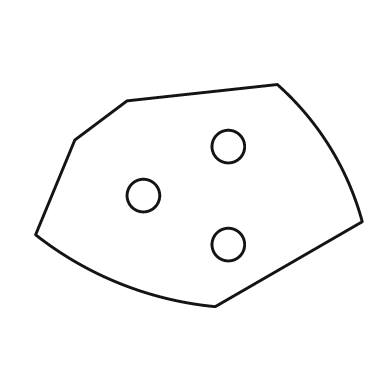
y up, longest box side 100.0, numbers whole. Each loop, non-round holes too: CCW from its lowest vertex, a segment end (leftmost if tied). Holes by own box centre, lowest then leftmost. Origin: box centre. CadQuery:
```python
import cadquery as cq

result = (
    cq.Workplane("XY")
    .moveTo(5.0, -34.0)
    .lineTo(50.0, -8.0)
    .threePointArc((40.0, 15.0), (24.0, 34.0))
    .lineTo(-22.0, 29.0)
    .lineTo(-38.0, 17.0)
    .lineTo(-50.0, -12.0)
    .threePointArc((-24.0, -27.0), (5.0, -34.0))
    .close()
    .moveTo(9.0, -15.0)
    .circle(5.0)
    .moveTo(-17.0, 0.0)
    .circle(5.0)
    .moveTo(9.0, 15.0)
    .circle(5.0)
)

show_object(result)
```